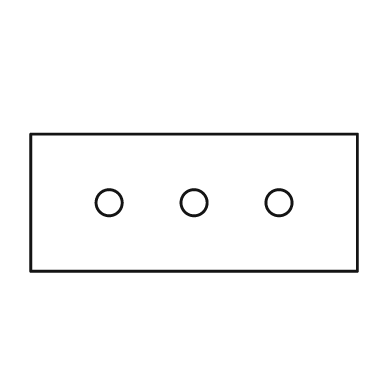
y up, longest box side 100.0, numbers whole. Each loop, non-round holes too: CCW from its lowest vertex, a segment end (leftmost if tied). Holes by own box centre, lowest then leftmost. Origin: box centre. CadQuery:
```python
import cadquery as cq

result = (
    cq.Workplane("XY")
    .moveTo(-50.0, -21.0)
    .lineTo(50.0, -21.0)
    .lineTo(50.0, 21.0)
    .lineTo(-50.0, 21.0)
    .close()
    .moveTo(-26.0, 0.0)
    .circle(4.0)
    .moveTo(0.0, 0.0)
    .circle(4.0)
    .moveTo(26.0, 0.0)
    .circle(4.0)
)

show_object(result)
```